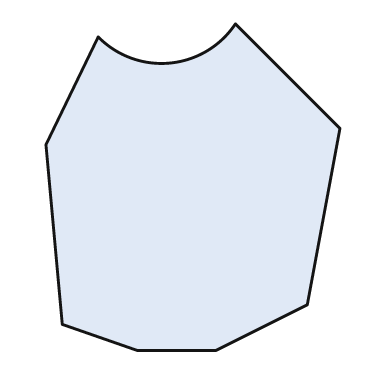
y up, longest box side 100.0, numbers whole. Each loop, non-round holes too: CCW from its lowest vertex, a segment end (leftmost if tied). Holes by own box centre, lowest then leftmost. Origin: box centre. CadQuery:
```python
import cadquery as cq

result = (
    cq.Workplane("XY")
    .moveTo(-17.0, -50.0)
    .lineTo(7.0, -50.0)
    .lineTo(35.0, -36.0)
    .lineTo(45.0, 18.0)
    .lineTo(13.0, 50.0)
    .threePointArc((-7.0, 38.0), (-29.0, 46.0))
    .lineTo(-45.0, 13.0)
    .lineTo(-40.0, -42.0)
    .close()
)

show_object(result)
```